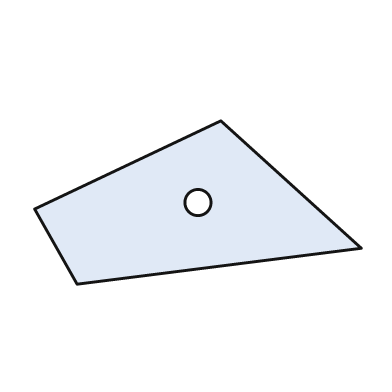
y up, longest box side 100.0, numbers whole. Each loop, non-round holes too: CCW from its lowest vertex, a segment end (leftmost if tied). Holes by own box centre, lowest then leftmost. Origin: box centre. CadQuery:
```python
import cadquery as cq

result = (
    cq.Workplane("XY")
    .moveTo(-37.0, -25.0)
    .lineTo(50.0, -14.0)
    .lineTo(7.0, 25.0)
    .lineTo(-50.0, -2.0)
    .close()
    .moveTo(0.0, 0.0)
    .circle(4.0)
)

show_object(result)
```